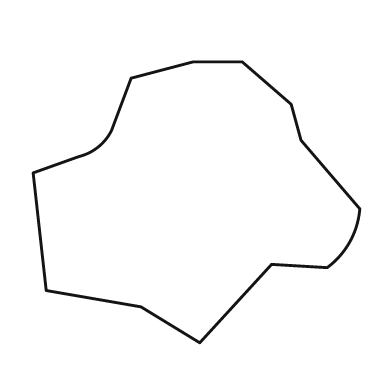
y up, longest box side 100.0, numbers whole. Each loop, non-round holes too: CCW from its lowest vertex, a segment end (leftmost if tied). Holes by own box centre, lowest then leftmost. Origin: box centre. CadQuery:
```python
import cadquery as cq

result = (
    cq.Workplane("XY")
    .moveTo(1.0, -43.0)
    .lineTo(23.0, -19.0)
    .lineTo(40.0, -20.0)
    .threePointArc((47.0, -12.0), (50.0, -2.0))
    .lineTo(32.0, 19.0)
    .lineTo(29.0, 30.0)
    .lineTo(14.0, 43.0)
    .lineTo(-1.0, 43.0)
    .lineTo(-20.0, 38.0)
    .lineTo(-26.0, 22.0)
    .threePointArc((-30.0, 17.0), (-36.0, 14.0))
    .lineTo(-50.0, 9.0)
    .lineTo(-46.0, -27.0)
    .lineTo(-17.0, -32.0)
    .close()
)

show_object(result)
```